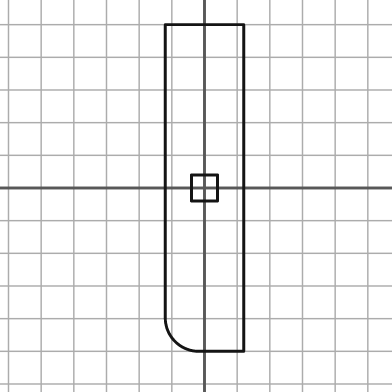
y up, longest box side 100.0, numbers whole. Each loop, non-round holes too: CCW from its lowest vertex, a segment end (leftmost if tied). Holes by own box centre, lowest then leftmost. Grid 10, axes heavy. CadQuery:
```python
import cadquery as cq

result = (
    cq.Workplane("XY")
    .moveTo(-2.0, -50.0)
    .lineTo(12.0, -50.0)
    .lineTo(12.0, 50.0)
    .lineTo(-12.0, 50.0)
    .lineTo(-12.0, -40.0)
    .threePointArc((-9.0, -47.0), (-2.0, -50.0))
    .close()
    .moveTo(-4.0, -4.0)
    .lineTo(4.0, -4.0)
    .lineTo(4.0, 4.0)
    .lineTo(-4.0, 4.0)
    .close()
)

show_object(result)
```